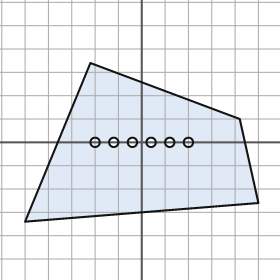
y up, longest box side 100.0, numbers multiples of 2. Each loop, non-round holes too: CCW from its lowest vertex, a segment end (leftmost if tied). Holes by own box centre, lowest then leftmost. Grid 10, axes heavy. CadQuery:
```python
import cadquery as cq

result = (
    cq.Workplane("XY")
    .moveTo(-50.0, -34.0)
    .lineTo(50.0, -26.0)
    .lineTo(42.0, 10.0)
    .lineTo(-22.0, 34.0)
    .close()
    .moveTo(-20.0, 0.0)
    .circle(2.0)
    .moveTo(-12.0, 0.0)
    .circle(2.0)
    .moveTo(-4.0, 0.0)
    .circle(2.0)
    .moveTo(4.0, 0.0)
    .circle(2.0)
    .moveTo(12.0, 0.0)
    .circle(2.0)
    .moveTo(20.0, 0.0)
    .circle(2.0)
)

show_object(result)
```